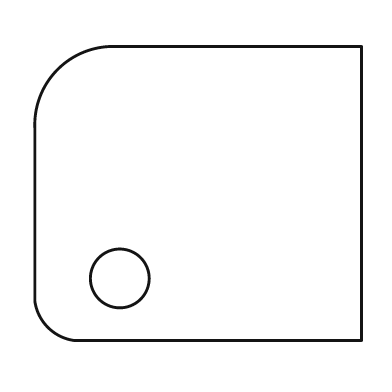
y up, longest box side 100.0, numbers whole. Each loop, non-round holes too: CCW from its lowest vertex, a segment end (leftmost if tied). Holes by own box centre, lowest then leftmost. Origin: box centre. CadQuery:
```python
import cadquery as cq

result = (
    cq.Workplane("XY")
    .moveTo(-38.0, -45.0)
    .lineTo(50.0, -45.0)
    .lineTo(50.0, 45.0)
    .lineTo(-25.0, 45.0)
    .threePointArc((-43.0, 38.0), (-50.0, 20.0))
    .lineTo(-50.0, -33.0)
    .threePointArc((-46.0, -41.0), (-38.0, -45.0))
    .close()
    .moveTo(-24.0, -26.0)
    .circle(9.0)
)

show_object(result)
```